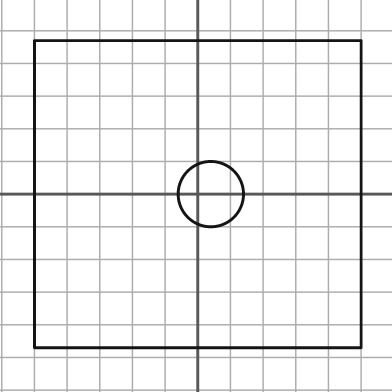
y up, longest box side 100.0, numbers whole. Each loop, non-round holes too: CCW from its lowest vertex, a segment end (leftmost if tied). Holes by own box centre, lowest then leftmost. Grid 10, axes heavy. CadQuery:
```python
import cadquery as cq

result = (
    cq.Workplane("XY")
    .moveTo(-50.0, -47.0)
    .lineTo(50.0, -47.0)
    .lineTo(50.0, 47.0)
    .lineTo(-50.0, 47.0)
    .close()
    .moveTo(4.0, 0.0)
    .circle(10.0)
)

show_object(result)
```